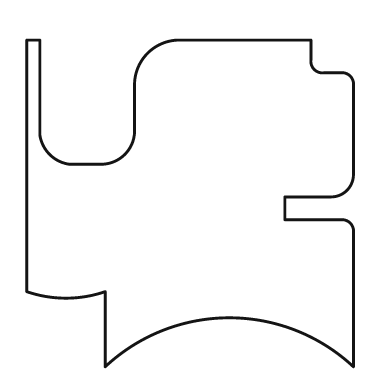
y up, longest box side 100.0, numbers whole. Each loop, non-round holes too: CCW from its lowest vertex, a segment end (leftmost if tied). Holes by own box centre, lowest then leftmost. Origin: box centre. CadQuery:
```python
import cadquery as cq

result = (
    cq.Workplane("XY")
    .moveTo(-26.0, -50.0)
    .threePointArc((12.0, -35.0), (50.0, -50.0))
    .lineTo(50.0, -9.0)
    .threePointArc((49.0, -6.0), (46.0, -5.0))
    .lineTo(29.0, -5.0)
    .lineTo(29.0, 2.0)
    .lineTo(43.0, 2.0)
    .threePointArc((48.0, 4.0), (50.0, 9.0))
    .lineTo(50.0, 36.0)
    .threePointArc((49.0, 39.0), (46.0, 40.0))
    .lineTo(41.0, 40.0)
    .threePointArc((38.0, 41.0), (37.0, 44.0))
    .lineTo(37.0, 50.0)
    .lineTo(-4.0, 50.0)
    .threePointArc((-13.0, 46.0), (-17.0, 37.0))
    .lineTo(-17.0, 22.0)
    .threePointArc((-20.0, 15.0), (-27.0, 12.0))
    .lineTo(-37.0, 12.0)
    .threePointArc((-43.0, 15.0), (-46.0, 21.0))
    .lineTo(-46.0, 50.0)
    .lineTo(-50.0, 50.0)
    .lineTo(-50.0, -27.0)
    .threePointArc((-38.0, -29.0), (-26.0, -27.0))
    .close()
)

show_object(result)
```